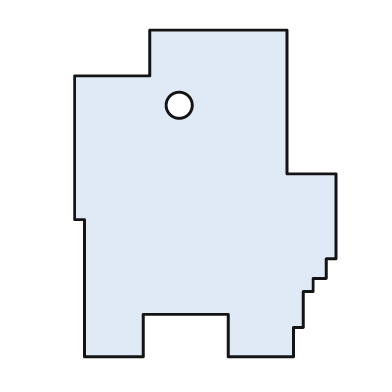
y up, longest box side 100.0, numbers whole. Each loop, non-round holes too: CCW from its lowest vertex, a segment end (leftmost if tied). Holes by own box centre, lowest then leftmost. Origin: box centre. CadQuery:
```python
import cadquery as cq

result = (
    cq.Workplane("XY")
    .moveTo(-37.0, -50.0)
    .lineTo(-19.0, -50.0)
    .lineTo(-19.0, -37.0)
    .lineTo(7.0, -37.0)
    .lineTo(7.0, -50.0)
    .lineTo(27.0, -50.0)
    .lineTo(27.0, -41.0)
    .lineTo(30.0, -41.0)
    .lineTo(30.0, -30.0)
    .lineTo(33.0, -30.0)
    .lineTo(33.0, -26.0)
    .lineTo(37.0, -26.0)
    .lineTo(37.0, -20.0)
    .lineTo(40.0, -20.0)
    .lineTo(40.0, 6.0)
    .lineTo(25.0, 6.0)
    .lineTo(25.0, 50.0)
    .lineTo(-17.0, 50.0)
    .lineTo(-17.0, 36.0)
    .lineTo(-40.0, 36.0)
    .lineTo(-40.0, -8.0)
    .lineTo(-37.0, -8.0)
    .close()
    .moveTo(-8.0, 27.0)
    .circle(4.0)
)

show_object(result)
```